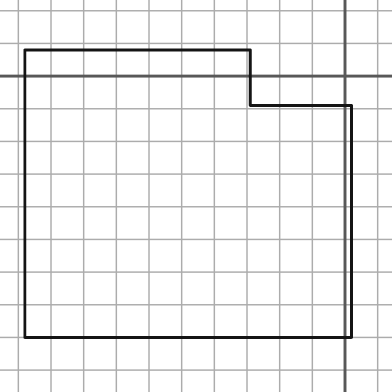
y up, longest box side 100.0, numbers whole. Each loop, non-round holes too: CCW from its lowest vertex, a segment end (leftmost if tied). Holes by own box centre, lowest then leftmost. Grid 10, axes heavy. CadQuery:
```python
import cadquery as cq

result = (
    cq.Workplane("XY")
    .moveTo(-98.0, -80.0)
    .lineTo(2.0, -80.0)
    .lineTo(2.0, -9.0)
    .lineTo(-29.0, -9.0)
    .lineTo(-29.0, 8.0)
    .lineTo(-98.0, 8.0)
    .close()
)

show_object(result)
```